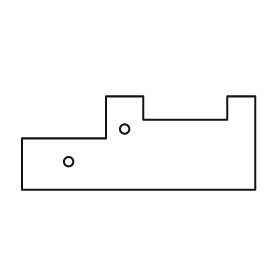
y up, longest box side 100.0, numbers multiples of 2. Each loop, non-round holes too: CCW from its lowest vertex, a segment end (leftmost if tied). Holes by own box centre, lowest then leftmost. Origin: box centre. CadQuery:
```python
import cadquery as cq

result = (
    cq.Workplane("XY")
    .moveTo(-50.0, -20.0)
    .lineTo(50.0, -20.0)
    .lineTo(50.0, 20.0)
    .lineTo(38.0, 20.0)
    .lineTo(38.0, 10.0)
    .lineTo(2.0, 10.0)
    .lineTo(2.0, 20.0)
    .lineTo(-14.0, 20.0)
    .lineTo(-14.0, 2.0)
    .lineTo(-50.0, 2.0)
    .close()
    .moveTo(-30.0, -8.0)
    .circle(2.0)
    .moveTo(-6.0, 6.0)
    .circle(2.0)
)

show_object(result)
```